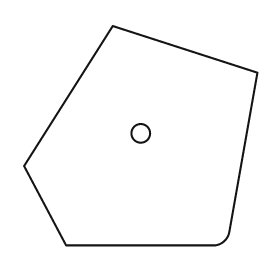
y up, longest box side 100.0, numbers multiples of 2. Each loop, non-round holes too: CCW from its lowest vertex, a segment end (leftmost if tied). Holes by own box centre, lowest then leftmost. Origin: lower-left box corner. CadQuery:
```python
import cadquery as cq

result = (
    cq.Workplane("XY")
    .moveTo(18.0, 0.0)
    .lineTo(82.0, 0.0)
    .threePointArc((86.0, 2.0), (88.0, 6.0))
    .lineTo(100.0, 74.0)
    .lineTo(38.0, 94.0)
    .lineTo(0.0, 34.0)
    .close()
    .moveTo(50.0, 48.0)
    .circle(4.0)
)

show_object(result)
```